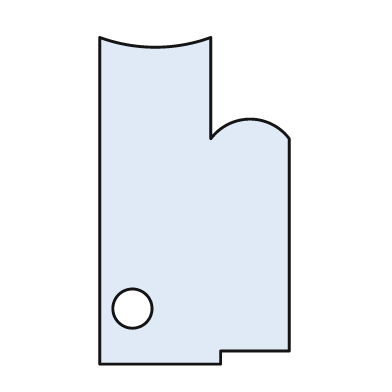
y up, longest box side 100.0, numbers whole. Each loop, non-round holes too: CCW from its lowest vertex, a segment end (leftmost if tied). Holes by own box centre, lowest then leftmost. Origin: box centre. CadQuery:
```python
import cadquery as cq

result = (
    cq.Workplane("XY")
    .moveTo(-29.0, -50.0)
    .lineTo(8.0, -50.0)
    .lineTo(8.0, -46.0)
    .lineTo(29.0, -46.0)
    .lineTo(29.0, 19.0)
    .threePointArc((17.0, 25.0), (5.0, 19.0))
    .lineTo(5.0, 50.0)
    .threePointArc((-12.0, 47.0), (-29.0, 50.0))
    .close()
    .moveTo(-19.0, -33.0)
    .circle(6.0)
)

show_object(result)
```